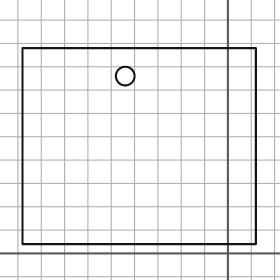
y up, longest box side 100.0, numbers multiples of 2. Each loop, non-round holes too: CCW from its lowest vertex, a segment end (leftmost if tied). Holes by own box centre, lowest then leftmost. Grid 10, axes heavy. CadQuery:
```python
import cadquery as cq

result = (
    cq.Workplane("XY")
    .moveTo(-88.0, 4.0)
    .lineTo(12.0, 4.0)
    .lineTo(12.0, 88.0)
    .lineTo(-88.0, 88.0)
    .close()
    .moveTo(-44.0, 76.0)
    .circle(4.0)
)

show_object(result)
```